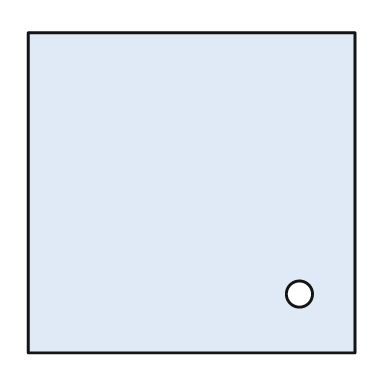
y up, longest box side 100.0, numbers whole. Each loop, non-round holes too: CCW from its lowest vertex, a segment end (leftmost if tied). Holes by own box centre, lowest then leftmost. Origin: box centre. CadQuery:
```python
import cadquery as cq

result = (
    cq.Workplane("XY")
    .moveTo(-50.0, -49.0)
    .lineTo(50.0, -49.0)
    .lineTo(50.0, 49.0)
    .lineTo(-50.0, 49.0)
    .close()
    .moveTo(33.0, -31.0)
    .circle(4.0)
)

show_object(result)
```